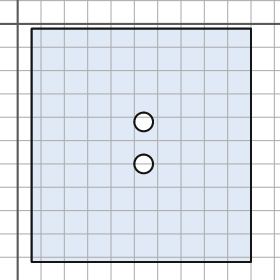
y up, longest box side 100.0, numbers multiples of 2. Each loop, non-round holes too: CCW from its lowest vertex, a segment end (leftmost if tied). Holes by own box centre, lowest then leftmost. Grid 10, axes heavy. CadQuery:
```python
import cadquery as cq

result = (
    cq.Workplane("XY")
    .moveTo(6.0, -102.0)
    .lineTo(100.0, -102.0)
    .lineTo(100.0, -2.0)
    .lineTo(6.0, -2.0)
    .close()
    .moveTo(54.0, -60.0)
    .circle(4.0)
    .moveTo(54.0, -42.0)
    .circle(4.0)
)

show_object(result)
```